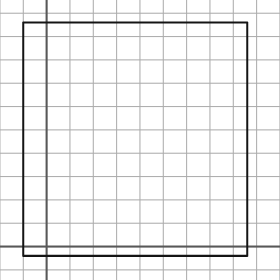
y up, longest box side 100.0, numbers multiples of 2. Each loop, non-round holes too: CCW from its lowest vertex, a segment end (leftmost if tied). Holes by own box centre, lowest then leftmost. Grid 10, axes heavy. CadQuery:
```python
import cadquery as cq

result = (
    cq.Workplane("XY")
    .moveTo(-10.0, -4.0)
    .lineTo(86.0, -4.0)
    .lineTo(86.0, 96.0)
    .lineTo(-10.0, 96.0)
    .close()
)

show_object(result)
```